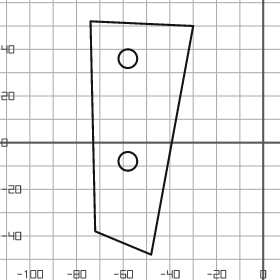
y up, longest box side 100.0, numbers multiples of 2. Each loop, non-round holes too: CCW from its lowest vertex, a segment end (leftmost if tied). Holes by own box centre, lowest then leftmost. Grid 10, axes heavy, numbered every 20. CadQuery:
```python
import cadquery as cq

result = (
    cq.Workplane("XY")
    .moveTo(-48.0, -48.0)
    .lineTo(-30.0, 50.0)
    .lineTo(-74.0, 52.0)
    .lineTo(-72.0, -38.0)
    .close()
    .moveTo(-58.0, -8.0)
    .circle(4.0)
    .moveTo(-58.0, 36.0)
    .circle(4.0)
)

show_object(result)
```